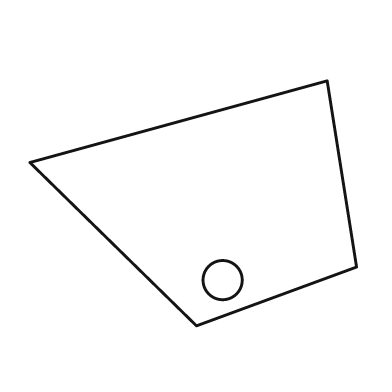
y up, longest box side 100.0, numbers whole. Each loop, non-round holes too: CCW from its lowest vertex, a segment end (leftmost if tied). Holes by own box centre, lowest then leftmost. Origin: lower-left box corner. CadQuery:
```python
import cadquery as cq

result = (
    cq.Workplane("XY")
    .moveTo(51.0, 0.0)
    .lineTo(100.0, 18.0)
    .lineTo(91.0, 75.0)
    .lineTo(0.0, 50.0)
    .close()
    .moveTo(59.0, 14.0)
    .circle(6.0)
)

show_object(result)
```